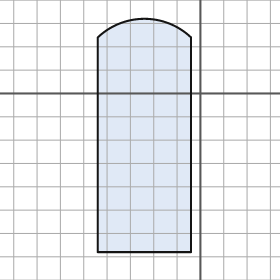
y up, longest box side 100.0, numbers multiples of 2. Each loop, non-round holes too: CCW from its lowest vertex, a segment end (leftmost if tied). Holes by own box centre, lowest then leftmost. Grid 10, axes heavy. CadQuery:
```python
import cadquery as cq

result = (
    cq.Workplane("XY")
    .moveTo(-44.0, -68.0)
    .lineTo(-4.0, -68.0)
    .lineTo(-4.0, 24.0)
    .threePointArc((-24.0, 32.0), (-44.0, 24.0))
    .close()
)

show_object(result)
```